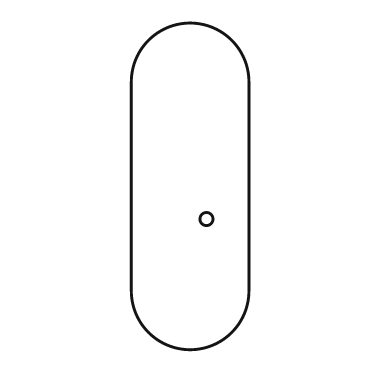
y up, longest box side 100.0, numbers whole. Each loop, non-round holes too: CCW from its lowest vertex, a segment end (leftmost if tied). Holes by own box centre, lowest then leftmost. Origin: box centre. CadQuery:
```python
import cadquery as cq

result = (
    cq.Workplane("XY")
    .moveTo(-18.0, -32.0)
    .threePointArc((0.0, -50.0), (18.0, -32.0))
    .lineTo(18.0, 32.0)
    .threePointArc((0.0, 50.0), (-18.0, 32.0))
    .close()
    .moveTo(5.0, -10.0)
    .circle(2.0)
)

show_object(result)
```